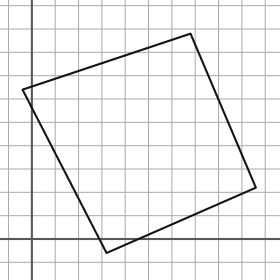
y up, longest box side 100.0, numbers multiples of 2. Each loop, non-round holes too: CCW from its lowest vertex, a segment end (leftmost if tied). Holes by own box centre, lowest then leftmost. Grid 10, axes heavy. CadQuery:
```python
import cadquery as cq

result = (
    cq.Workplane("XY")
    .moveTo(32.0, -6.0)
    .lineTo(96.0, 22.0)
    .lineTo(68.0, 88.0)
    .lineTo(-4.0, 64.0)
    .close()
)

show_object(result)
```